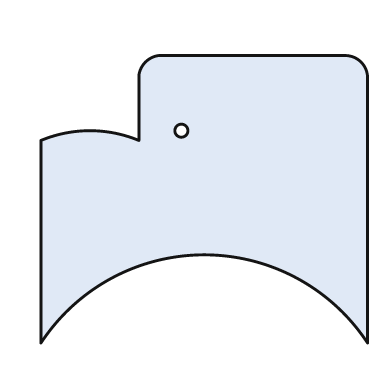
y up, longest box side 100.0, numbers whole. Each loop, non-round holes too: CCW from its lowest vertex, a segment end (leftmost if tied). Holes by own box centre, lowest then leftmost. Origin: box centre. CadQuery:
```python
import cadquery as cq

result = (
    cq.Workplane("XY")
    .moveTo(-50.0, -44.0)
    .threePointArc((0.0, -17.0), (50.0, -44.0))
    .lineTo(50.0, 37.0)
    .threePointArc((48.0, 42.0), (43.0, 44.0))
    .lineTo(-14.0, 44.0)
    .threePointArc((-18.0, 42.0), (-20.0, 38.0))
    .lineTo(-20.0, 18.0)
    .threePointArc((-35.0, 21.0), (-50.0, 18.0))
    .close()
    .moveTo(-7.0, 21.0)
    .circle(2.0)
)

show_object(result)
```